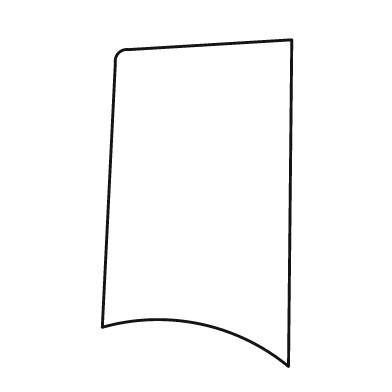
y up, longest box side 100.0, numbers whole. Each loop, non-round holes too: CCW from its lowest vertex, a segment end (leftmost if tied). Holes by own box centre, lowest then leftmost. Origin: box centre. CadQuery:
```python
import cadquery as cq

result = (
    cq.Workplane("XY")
    .moveTo(28.0, -50.0)
    .lineTo(29.0, 50.0)
    .lineTo(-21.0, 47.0)
    .threePointArc((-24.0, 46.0), (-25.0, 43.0))
    .lineTo(-29.0, -38.0)
    .threePointArc((1.0, -37.0), (28.0, -50.0))
    .close()
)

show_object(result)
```